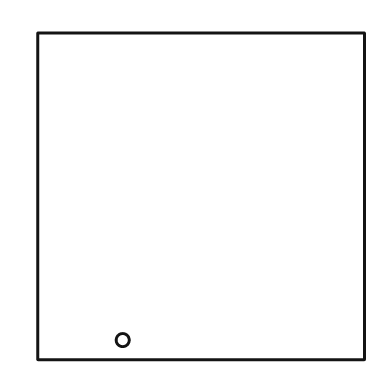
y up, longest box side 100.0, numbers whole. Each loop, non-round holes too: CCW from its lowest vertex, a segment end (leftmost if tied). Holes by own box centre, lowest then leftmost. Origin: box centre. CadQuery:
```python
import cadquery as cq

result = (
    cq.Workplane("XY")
    .moveTo(-50.0, -50.0)
    .lineTo(50.0, -50.0)
    .lineTo(50.0, 50.0)
    .lineTo(-50.0, 50.0)
    .close()
    .moveTo(-24.0, -44.0)
    .circle(2.0)
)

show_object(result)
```